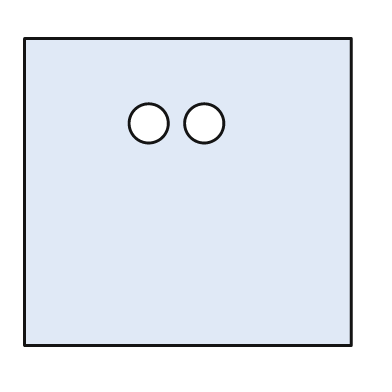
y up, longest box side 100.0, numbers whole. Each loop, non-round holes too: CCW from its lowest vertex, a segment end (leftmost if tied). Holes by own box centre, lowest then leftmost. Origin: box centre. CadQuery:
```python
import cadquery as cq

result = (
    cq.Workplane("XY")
    .moveTo(-50.0, -47.0)
    .lineTo(50.0, -47.0)
    .lineTo(50.0, 47.0)
    .lineTo(-50.0, 47.0)
    .close()
    .moveTo(-12.0, 21.0)
    .circle(6.0)
    .moveTo(5.0, 21.0)
    .circle(6.0)
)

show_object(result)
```